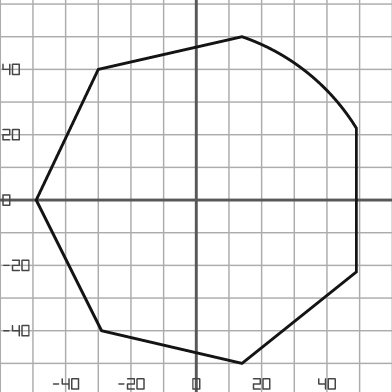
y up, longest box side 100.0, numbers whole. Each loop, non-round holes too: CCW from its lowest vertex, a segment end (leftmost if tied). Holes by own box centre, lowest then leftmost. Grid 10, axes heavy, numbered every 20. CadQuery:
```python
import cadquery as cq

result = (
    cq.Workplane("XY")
    .moveTo(14.0, -50.0)
    .lineTo(49.0, -22.0)
    .lineTo(49.0, 22.0)
    .threePointArc((34.0, 39.0), (14.0, 50.0))
    .lineTo(-30.0, 40.0)
    .lineTo(-49.0, 0.0)
    .lineTo(-29.0, -40.0)
    .close()
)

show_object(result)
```